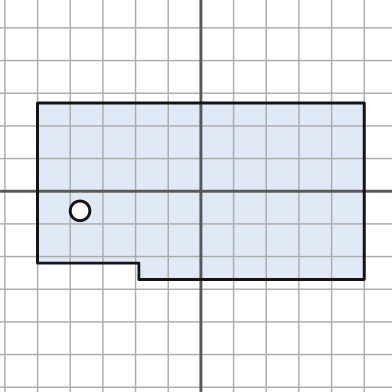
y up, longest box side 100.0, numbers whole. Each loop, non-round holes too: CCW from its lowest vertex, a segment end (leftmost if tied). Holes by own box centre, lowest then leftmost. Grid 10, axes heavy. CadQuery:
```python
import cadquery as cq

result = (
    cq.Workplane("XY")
    .moveTo(-19.0, -27.0)
    .lineTo(50.0, -27.0)
    .lineTo(50.0, 27.0)
    .lineTo(-50.0, 27.0)
    .lineTo(-50.0, -22.0)
    .lineTo(-19.0, -22.0)
    .close()
    .moveTo(-37.0, -6.0)
    .circle(3.0)
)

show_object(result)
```